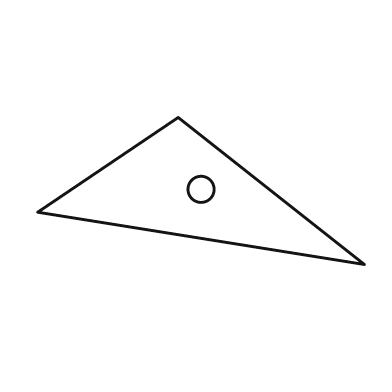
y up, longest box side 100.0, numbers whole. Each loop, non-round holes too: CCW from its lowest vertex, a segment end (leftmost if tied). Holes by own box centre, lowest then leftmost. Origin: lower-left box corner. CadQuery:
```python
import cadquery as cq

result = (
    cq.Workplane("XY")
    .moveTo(100.0, 0.0)
    .lineTo(43.0, 45.0)
    .lineTo(0.0, 16.0)
    .close()
    .moveTo(50.0, 23.0)
    .circle(4.0)
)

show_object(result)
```